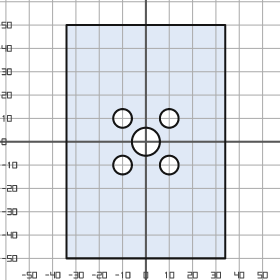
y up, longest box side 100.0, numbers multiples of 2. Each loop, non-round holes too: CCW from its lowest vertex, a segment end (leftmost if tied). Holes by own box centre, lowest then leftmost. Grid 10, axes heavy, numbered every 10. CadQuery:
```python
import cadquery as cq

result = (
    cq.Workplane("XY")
    .moveTo(-34.0, -50.0)
    .lineTo(34.0, -50.0)
    .lineTo(34.0, 50.0)
    .lineTo(-34.0, 50.0)
    .close()
    .moveTo(-10.0, -10.0)
    .circle(4.0)
    .moveTo(10.0, -10.0)
    .circle(4.0)
    .moveTo(0.0, 0.0)
    .circle(6.0)
    .moveTo(-10.0, 10.0)
    .circle(4.0)
    .moveTo(10.0, 10.0)
    .circle(4.0)
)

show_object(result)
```